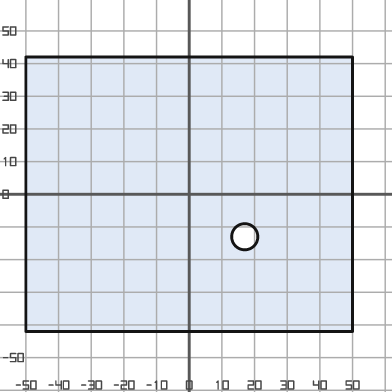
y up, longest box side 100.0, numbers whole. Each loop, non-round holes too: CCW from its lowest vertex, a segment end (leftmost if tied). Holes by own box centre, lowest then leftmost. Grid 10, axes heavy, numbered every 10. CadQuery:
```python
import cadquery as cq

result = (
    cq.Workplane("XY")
    .moveTo(-50.0, -42.0)
    .lineTo(50.0, -42.0)
    .lineTo(50.0, 42.0)
    .lineTo(-50.0, 42.0)
    .close()
    .moveTo(17.0, -13.0)
    .circle(4.0)
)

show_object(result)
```